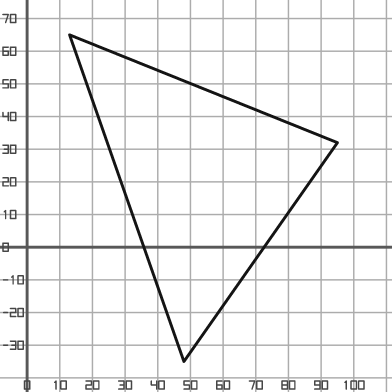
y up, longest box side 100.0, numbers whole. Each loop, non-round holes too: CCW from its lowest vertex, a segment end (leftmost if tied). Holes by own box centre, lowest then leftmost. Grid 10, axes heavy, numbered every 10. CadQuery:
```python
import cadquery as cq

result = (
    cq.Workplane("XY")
    .moveTo(48.0, -35.0)
    .lineTo(95.0, 32.0)
    .lineTo(13.0, 65.0)
    .close()
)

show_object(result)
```